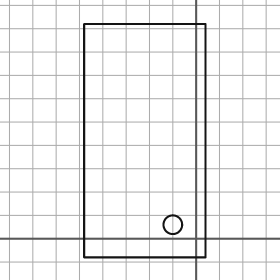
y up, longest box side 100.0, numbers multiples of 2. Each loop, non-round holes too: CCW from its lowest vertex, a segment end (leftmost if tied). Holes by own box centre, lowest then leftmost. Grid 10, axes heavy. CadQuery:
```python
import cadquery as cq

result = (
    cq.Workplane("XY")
    .moveTo(-48.0, -8.0)
    .lineTo(4.0, -8.0)
    .lineTo(4.0, 92.0)
    .lineTo(-48.0, 92.0)
    .close()
    .moveTo(-10.0, 6.0)
    .circle(4.0)
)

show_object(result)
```